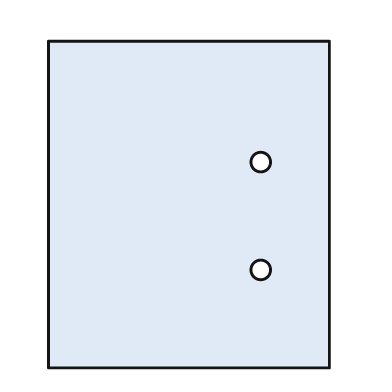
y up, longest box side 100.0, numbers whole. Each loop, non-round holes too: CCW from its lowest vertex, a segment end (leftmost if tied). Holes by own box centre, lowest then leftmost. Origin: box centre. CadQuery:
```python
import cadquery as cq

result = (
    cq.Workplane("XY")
    .moveTo(-43.0, -50.0)
    .lineTo(43.0, -50.0)
    .lineTo(43.0, 50.0)
    .lineTo(-43.0, 50.0)
    .close()
    .moveTo(22.0, -20.0)
    .circle(3.0)
    .moveTo(22.0, 13.0)
    .circle(3.0)
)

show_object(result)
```